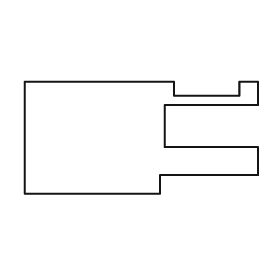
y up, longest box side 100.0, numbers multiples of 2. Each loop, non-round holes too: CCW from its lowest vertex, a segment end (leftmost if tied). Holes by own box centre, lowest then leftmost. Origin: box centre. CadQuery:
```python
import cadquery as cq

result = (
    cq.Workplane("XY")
    .moveTo(-50.0, -24.0)
    .lineTo(8.0, -24.0)
    .lineTo(8.0, -16.0)
    .lineTo(50.0, -16.0)
    .lineTo(50.0, -4.0)
    .lineTo(10.0, -4.0)
    .lineTo(10.0, 14.0)
    .lineTo(50.0, 14.0)
    .lineTo(50.0, 24.0)
    .lineTo(42.0, 24.0)
    .lineTo(42.0, 18.0)
    .lineTo(14.0, 18.0)
    .lineTo(14.0, 24.0)
    .lineTo(-50.0, 24.0)
    .close()
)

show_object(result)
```